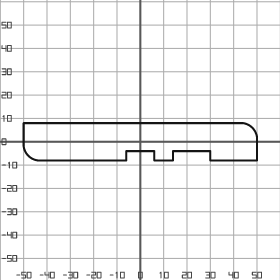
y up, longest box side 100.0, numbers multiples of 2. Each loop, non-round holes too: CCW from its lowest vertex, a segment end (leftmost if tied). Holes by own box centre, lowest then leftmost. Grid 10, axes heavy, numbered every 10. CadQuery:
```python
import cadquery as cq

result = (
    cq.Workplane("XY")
    .moveTo(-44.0, -8.0)
    .lineTo(-6.0, -8.0)
    .lineTo(-6.0, -4.0)
    .lineTo(6.0, -4.0)
    .lineTo(6.0, -8.0)
    .lineTo(14.0, -8.0)
    .lineTo(14.0, -4.0)
    .lineTo(30.0, -4.0)
    .lineTo(30.0, -8.0)
    .lineTo(50.0, -8.0)
    .lineTo(50.0, 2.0)
    .threePointArc((48.0, 6.0), (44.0, 8.0))
    .lineTo(-50.0, 8.0)
    .lineTo(-50.0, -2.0)
    .threePointArc((-48.0, -6.0), (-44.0, -8.0))
    .close()
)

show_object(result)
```